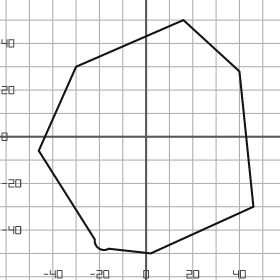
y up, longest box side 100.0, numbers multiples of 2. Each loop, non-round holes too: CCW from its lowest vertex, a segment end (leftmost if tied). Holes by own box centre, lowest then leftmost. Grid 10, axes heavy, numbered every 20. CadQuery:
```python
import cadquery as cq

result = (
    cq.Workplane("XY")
    .moveTo(2.0, -50.0)
    .lineTo(46.0, -30.0)
    .lineTo(40.0, 28.0)
    .lineTo(16.0, 50.0)
    .lineTo(-30.0, 30.0)
    .lineTo(-46.0, -6.0)
    .lineTo(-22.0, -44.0)
    .threePointArc((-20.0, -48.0), (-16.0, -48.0))
    .close()
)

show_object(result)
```